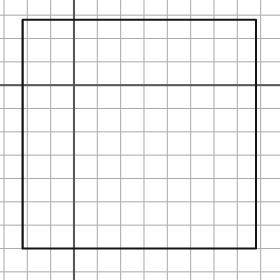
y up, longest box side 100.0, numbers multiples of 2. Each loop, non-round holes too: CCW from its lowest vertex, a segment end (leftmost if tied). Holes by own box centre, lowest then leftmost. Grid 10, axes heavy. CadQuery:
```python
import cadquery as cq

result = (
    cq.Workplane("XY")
    .moveTo(-22.0, -70.0)
    .lineTo(78.0, -70.0)
    .lineTo(78.0, 28.0)
    .lineTo(-22.0, 28.0)
    .close()
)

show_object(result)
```